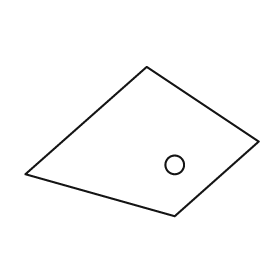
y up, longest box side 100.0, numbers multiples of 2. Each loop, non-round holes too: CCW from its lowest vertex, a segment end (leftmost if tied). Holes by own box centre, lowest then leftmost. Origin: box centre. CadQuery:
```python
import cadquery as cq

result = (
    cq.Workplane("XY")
    .moveTo(14.0, -32.0)
    .lineTo(50.0, 0.0)
    .lineTo(2.0, 32.0)
    .lineTo(-50.0, -14.0)
    .close()
    .moveTo(14.0, -10.0)
    .circle(4.0)
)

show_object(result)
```